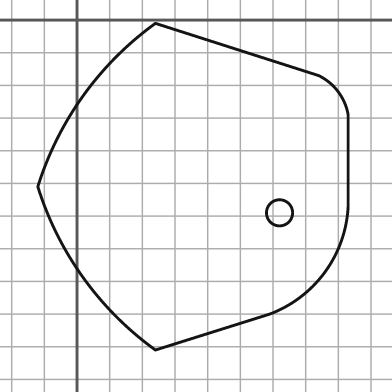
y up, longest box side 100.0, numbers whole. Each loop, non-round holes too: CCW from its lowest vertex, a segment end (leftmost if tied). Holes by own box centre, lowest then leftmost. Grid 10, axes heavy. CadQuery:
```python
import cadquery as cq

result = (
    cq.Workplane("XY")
    .moveTo(24.0, -101.0)
    .lineTo(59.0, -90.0)
    .threePointArc((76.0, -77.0), (83.0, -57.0))
    .lineTo(83.0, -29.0)
    .threePointArc((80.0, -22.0), (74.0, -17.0))
    .lineTo(24.0, -1.0)
    .threePointArc((2.0, -23.0), (-12.0, -51.0))
    .threePointArc((2.0, -79.0), (24.0, -101.0))
    .close()
    .moveTo(62.0, -59.0)
    .circle(4.0)
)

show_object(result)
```